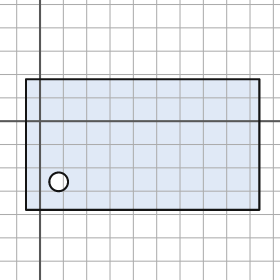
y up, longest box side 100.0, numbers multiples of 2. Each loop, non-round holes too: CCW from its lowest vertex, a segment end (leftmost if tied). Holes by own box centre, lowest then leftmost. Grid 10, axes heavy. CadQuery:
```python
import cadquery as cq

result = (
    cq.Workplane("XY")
    .moveTo(-6.0, -38.0)
    .lineTo(94.0, -38.0)
    .lineTo(94.0, 18.0)
    .lineTo(-6.0, 18.0)
    .close()
    .moveTo(8.0, -26.0)
    .circle(4.0)
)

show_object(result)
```